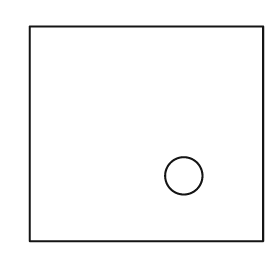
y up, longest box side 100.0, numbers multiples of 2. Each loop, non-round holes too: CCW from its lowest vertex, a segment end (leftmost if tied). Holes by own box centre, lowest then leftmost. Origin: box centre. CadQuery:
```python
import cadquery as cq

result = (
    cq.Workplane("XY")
    .moveTo(-50.0, -46.0)
    .lineTo(50.0, -46.0)
    .lineTo(50.0, 46.0)
    .lineTo(-50.0, 46.0)
    .close()
    .moveTo(16.0, -18.0)
    .circle(8.0)
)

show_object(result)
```